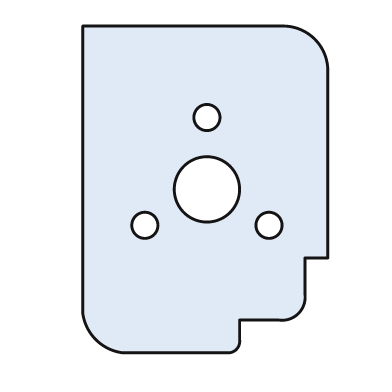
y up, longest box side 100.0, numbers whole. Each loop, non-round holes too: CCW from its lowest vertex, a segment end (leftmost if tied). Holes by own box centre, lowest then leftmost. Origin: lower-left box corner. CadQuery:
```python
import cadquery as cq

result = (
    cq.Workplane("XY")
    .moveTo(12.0, 0.0)
    .lineTo(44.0, 0.0)
    .threePointArc((47.0, 1.0), (48.0, 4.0))
    .lineTo(48.0, 10.0)
    .lineTo(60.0, 10.0)
    .threePointArc((66.0, 12.0), (68.0, 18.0))
    .lineTo(68.0, 29.0)
    .lineTo(75.0, 29.0)
    .lineTo(75.0, 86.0)
    .threePointArc((71.0, 96.0), (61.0, 100.0))
    .lineTo(0.0, 100.0)
    .lineTo(0.0, 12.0)
    .threePointArc((4.0, 4.0), (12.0, 0.0))
    .close()
    .moveTo(19.0, 39.0)
    .circle(4.0)
    .moveTo(57.0, 39.0)
    .circle(4.0)
    .moveTo(38.0, 50.0)
    .circle(10.0)
    .moveTo(38.0, 72.0)
    .circle(4.0)
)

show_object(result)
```